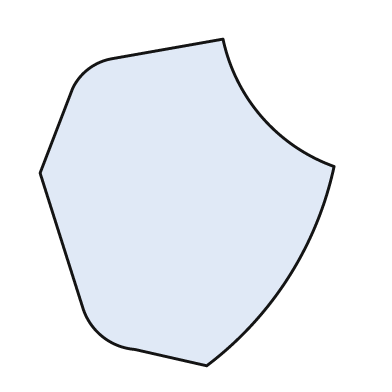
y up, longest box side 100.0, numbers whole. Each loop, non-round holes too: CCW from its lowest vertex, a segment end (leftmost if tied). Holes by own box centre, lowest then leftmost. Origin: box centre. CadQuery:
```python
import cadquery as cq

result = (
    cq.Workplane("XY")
    .moveTo(6.0, -50.0)
    .threePointArc((31.0, -23.0), (45.0, 11.0))
    .threePointArc((23.0, 26.0), (11.0, 50.0))
    .lineTo(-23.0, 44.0)
    .threePointArc((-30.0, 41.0), (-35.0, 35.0))
    .lineTo(-45.0, 9.0)
    .lineTo(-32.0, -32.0)
    .threePointArc((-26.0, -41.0), (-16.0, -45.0))
    .close()
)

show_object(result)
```